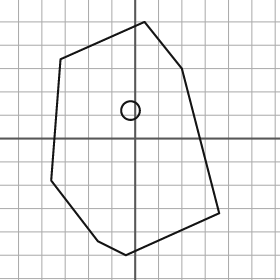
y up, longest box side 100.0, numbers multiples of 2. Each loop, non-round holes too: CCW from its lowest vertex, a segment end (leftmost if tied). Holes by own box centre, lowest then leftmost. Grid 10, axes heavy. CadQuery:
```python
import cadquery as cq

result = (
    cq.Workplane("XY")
    .moveTo(-4.0, -50.0)
    .lineTo(36.0, -32.0)
    .lineTo(20.0, 30.0)
    .lineTo(4.0, 50.0)
    .lineTo(-32.0, 34.0)
    .lineTo(-36.0, -18.0)
    .lineTo(-16.0, -44.0)
    .close()
    .moveTo(-2.0, 12.0)
    .circle(4.0)
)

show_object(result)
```